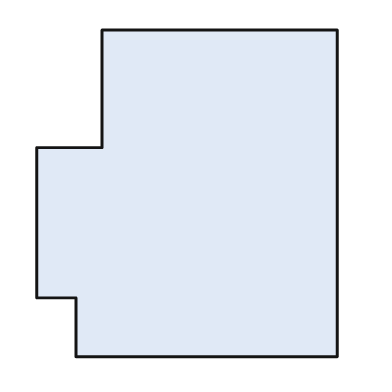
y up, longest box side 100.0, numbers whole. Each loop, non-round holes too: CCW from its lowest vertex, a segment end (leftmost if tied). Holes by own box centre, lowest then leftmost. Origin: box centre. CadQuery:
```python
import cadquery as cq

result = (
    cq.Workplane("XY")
    .moveTo(-34.0, -50.0)
    .lineTo(46.0, -50.0)
    .lineTo(46.0, 50.0)
    .lineTo(-26.0, 50.0)
    .lineTo(-26.0, 14.0)
    .lineTo(-46.0, 14.0)
    .lineTo(-46.0, -32.0)
    .lineTo(-34.0, -32.0)
    .close()
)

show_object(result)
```